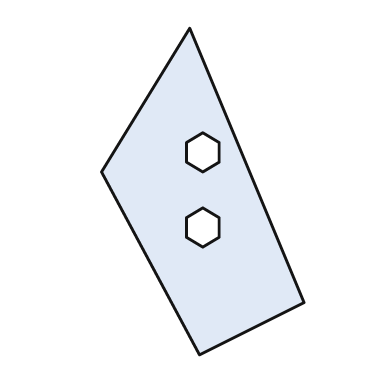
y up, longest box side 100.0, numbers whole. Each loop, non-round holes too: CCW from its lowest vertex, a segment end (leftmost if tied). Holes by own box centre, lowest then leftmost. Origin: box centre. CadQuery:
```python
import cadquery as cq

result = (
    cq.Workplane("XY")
    .moveTo(-1.0, -50.0)
    .lineTo(31.0, -34.0)
    .lineTo(-4.0, 50.0)
    .lineTo(-31.0, 6.0)
    .close()
    .moveTo(0.0, -17.0)
    .lineTo(5.0, -14.0)
    .lineTo(5.0, -8.0)
    .lineTo(0.0, -5.0)
    .lineTo(-5.0, -8.0)
    .lineTo(-5.0, -14.0)
    .close()
    .moveTo(0.0, 6.0)
    .lineTo(5.0, 9.0)
    .lineTo(5.0, 15.0)
    .lineTo(0.0, 18.0)
    .lineTo(-5.0, 15.0)
    .lineTo(-5.0, 9.0)
    .close()
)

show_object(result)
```